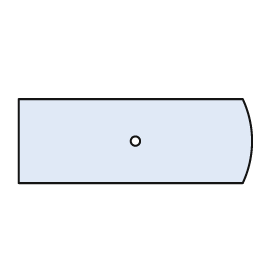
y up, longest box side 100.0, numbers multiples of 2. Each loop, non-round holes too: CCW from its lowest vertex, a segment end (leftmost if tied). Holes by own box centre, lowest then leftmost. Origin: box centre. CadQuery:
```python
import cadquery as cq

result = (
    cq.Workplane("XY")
    .moveTo(-50.0, -18.0)
    .lineTo(46.0, -18.0)
    .threePointArc((50.0, 0.0), (46.0, 18.0))
    .lineTo(-50.0, 18.0)
    .close()
    .moveTo(0.0, 0.0)
    .circle(2.0)
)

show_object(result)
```